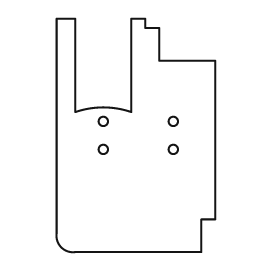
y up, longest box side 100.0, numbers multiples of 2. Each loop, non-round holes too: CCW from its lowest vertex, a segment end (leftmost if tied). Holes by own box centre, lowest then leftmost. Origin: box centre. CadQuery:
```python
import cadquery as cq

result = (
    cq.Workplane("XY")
    .moveTo(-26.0, -50.0)
    .lineTo(28.0, -50.0)
    .lineTo(28.0, -36.0)
    .lineTo(34.0, -36.0)
    .lineTo(34.0, 32.0)
    .lineTo(10.0, 32.0)
    .lineTo(10.0, 46.0)
    .lineTo(4.0, 46.0)
    .lineTo(4.0, 50.0)
    .lineTo(-2.0, 50.0)
    .lineTo(-2.0, 10.0)
    .threePointArc((-14.0, 12.0), (-26.0, 10.0))
    .lineTo(-26.0, 50.0)
    .lineTo(-34.0, 50.0)
    .lineTo(-34.0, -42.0)
    .threePointArc((-32.0, -48.0), (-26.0, -50.0))
    .close()
    .moveTo(-14.0, -6.0)
    .circle(2.0)
    .moveTo(16.0, -6.0)
    .circle(2.0)
    .moveTo(-14.0, 6.0)
    .circle(2.0)
    .moveTo(16.0, 6.0)
    .circle(2.0)
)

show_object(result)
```